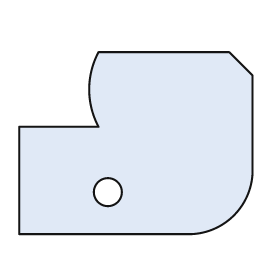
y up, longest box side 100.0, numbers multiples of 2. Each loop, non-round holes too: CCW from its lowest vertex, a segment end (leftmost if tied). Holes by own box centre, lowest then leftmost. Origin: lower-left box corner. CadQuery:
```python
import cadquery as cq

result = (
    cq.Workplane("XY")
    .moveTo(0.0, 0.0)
    .lineTo(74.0, 0.0)
    .threePointArc((92.0, 8.0), (100.0, 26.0))
    .lineTo(100.0, 68.0)
    .lineTo(90.0, 78.0)
    .lineTo(34.0, 78.0)
    .threePointArc((30.0, 62.0), (34.0, 46.0))
    .lineTo(0.0, 46.0)
    .close()
    .moveTo(38.0, 18.0)
    .circle(6.0)
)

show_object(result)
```